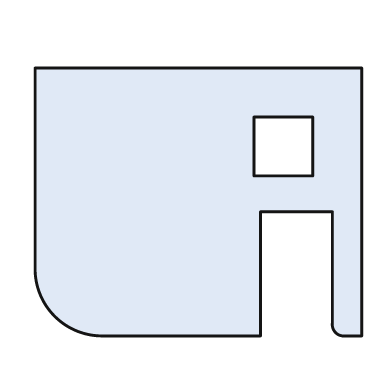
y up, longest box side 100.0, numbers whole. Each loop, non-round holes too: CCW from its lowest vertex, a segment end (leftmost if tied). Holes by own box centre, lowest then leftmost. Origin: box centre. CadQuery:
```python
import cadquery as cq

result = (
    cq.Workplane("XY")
    .moveTo(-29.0, -41.0)
    .lineTo(19.0, -41.0)
    .lineTo(19.0, -3.0)
    .lineTo(41.0, -3.0)
    .lineTo(41.0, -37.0)
    .threePointArc((42.0, -40.0), (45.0, -41.0))
    .lineTo(50.0, -41.0)
    .lineTo(50.0, 41.0)
    .lineTo(-50.0, 41.0)
    .lineTo(-50.0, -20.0)
    .threePointArc((-44.0, -35.0), (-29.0, -41.0))
    .close()
    .moveTo(17.0, 8.0)
    .lineTo(35.0, 8.0)
    .lineTo(35.0, 26.0)
    .lineTo(17.0, 26.0)
    .close()
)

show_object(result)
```